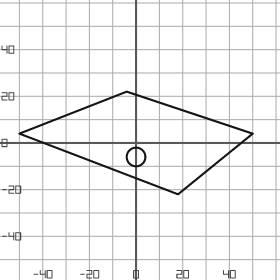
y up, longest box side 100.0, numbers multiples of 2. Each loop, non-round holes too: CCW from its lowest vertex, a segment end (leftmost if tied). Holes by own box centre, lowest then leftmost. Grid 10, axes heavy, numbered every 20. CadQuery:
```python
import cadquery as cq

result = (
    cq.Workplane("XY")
    .moveTo(18.0, -22.0)
    .lineTo(50.0, 4.0)
    .lineTo(-4.0, 22.0)
    .lineTo(-50.0, 4.0)
    .close()
    .moveTo(0.0, -6.0)
    .circle(4.0)
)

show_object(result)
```